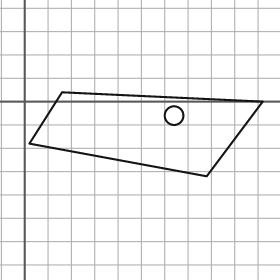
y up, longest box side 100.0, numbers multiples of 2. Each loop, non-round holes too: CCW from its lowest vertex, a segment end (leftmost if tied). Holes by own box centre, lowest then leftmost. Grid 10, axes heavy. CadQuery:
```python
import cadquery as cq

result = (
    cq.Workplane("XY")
    .moveTo(78.0, -32.0)
    .lineTo(102.0, 0.0)
    .lineTo(16.0, 4.0)
    .lineTo(2.0, -18.0)
    .close()
    .moveTo(64.0, -6.0)
    .circle(4.0)
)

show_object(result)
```